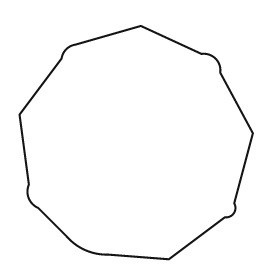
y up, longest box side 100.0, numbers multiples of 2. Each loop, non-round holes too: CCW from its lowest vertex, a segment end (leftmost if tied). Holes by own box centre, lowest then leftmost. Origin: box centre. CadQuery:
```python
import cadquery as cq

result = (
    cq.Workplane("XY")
    .moveTo(14.0, -50.0)
    .lineTo(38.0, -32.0)
    .threePointArc((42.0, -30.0), (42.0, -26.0))
    .lineTo(50.0, 4.0)
    .lineTo(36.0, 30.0)
    .threePointArc((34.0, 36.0), (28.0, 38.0))
    .lineTo(2.0, 50.0)
    .lineTo(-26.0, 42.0)
    .threePointArc((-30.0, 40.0), (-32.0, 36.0))
    .lineTo(-50.0, 12.0)
    .lineTo(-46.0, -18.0)
    .threePointArc((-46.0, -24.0), (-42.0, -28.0))
    .lineTo(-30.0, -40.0)
    .threePointArc((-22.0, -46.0), (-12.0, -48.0))
    .close()
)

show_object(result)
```